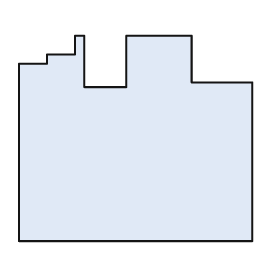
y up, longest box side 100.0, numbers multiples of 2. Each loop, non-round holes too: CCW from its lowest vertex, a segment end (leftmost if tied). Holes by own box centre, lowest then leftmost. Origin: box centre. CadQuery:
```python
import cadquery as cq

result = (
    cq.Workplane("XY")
    .moveTo(-50.0, -44.0)
    .lineTo(50.0, -44.0)
    .lineTo(50.0, 24.0)
    .lineTo(24.0, 24.0)
    .lineTo(24.0, 44.0)
    .lineTo(-4.0, 44.0)
    .lineTo(-4.0, 22.0)
    .lineTo(-22.0, 22.0)
    .lineTo(-22.0, 44.0)
    .lineTo(-26.0, 44.0)
    .lineTo(-26.0, 36.0)
    .lineTo(-38.0, 36.0)
    .lineTo(-38.0, 32.0)
    .lineTo(-50.0, 32.0)
    .close()
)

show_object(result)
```